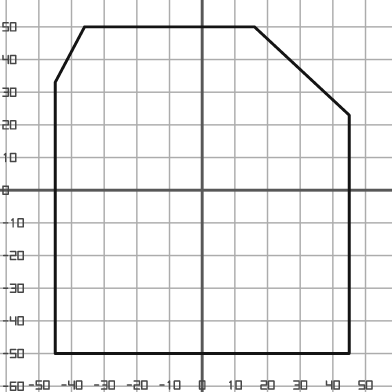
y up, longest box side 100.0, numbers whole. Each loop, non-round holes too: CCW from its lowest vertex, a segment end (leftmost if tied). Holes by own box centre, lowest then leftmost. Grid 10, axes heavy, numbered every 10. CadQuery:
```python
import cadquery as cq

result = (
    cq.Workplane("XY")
    .moveTo(-45.0, -50.0)
    .lineTo(45.0, -50.0)
    .lineTo(45.0, 23.0)
    .lineTo(16.0, 50.0)
    .lineTo(-36.0, 50.0)
    .lineTo(-45.0, 33.0)
    .close()
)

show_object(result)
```